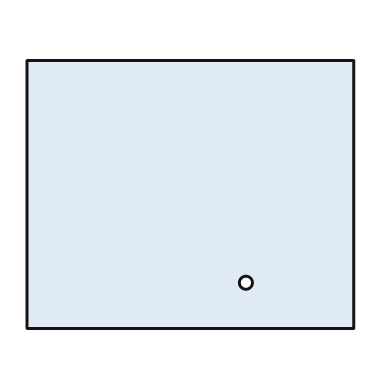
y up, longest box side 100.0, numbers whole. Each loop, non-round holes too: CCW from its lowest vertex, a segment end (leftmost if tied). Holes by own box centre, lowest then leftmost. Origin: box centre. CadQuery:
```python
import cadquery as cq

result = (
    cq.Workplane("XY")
    .moveTo(-50.0, -41.0)
    .lineTo(50.0, -41.0)
    .lineTo(50.0, 41.0)
    .lineTo(-50.0, 41.0)
    .close()
    .moveTo(17.0, -27.0)
    .circle(2.0)
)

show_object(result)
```